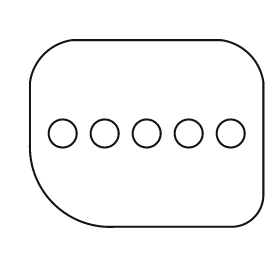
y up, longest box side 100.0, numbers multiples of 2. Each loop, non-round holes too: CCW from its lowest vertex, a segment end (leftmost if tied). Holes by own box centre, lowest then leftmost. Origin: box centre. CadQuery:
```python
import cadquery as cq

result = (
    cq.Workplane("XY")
    .moveTo(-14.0, -40.0)
    .lineTo(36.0, -40.0)
    .threePointArc((46.0, -36.0), (50.0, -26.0))
    .lineTo(50.0, 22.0)
    .threePointArc((44.0, 34.0), (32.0, 40.0))
    .lineTo(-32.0, 40.0)
    .threePointArc((-44.0, 34.0), (-50.0, 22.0))
    .lineTo(-50.0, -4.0)
    .threePointArc((-40.0, -30.0), (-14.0, -40.0))
    .close()
    .moveTo(-36.0, 0.0)
    .circle(6.0)
    .moveTo(-18.0, 0.0)
    .circle(6.0)
    .moveTo(0.0, 0.0)
    .circle(6.0)
    .moveTo(18.0, 0.0)
    .circle(6.0)
    .moveTo(36.0, 0.0)
    .circle(6.0)
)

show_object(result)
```